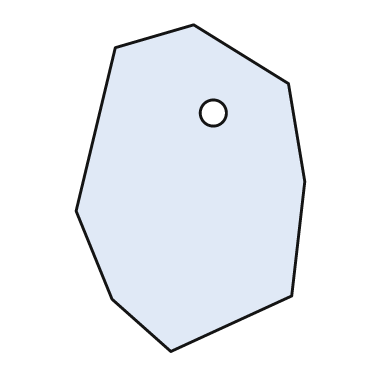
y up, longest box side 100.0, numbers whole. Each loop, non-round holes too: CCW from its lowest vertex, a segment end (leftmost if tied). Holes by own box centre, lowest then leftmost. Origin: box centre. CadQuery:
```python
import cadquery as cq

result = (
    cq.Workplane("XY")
    .moveTo(-6.0, -50.0)
    .lineTo(31.0, -33.0)
    .lineTo(35.0, 2.0)
    .lineTo(30.0, 32.0)
    .lineTo(1.0, 50.0)
    .lineTo(-23.0, 43.0)
    .lineTo(-35.0, -7.0)
    .lineTo(-24.0, -34.0)
    .close()
    .moveTo(7.0, 23.0)
    .circle(4.0)
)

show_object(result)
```